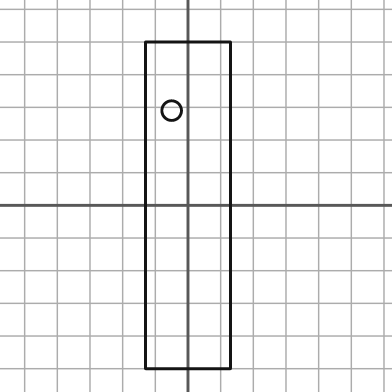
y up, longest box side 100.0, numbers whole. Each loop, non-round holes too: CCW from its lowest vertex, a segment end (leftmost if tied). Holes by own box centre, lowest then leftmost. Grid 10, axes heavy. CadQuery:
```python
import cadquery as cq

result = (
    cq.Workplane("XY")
    .moveTo(-13.0, -50.0)
    .lineTo(13.0, -50.0)
    .lineTo(13.0, 50.0)
    .lineTo(-13.0, 50.0)
    .close()
    .moveTo(-5.0, 29.0)
    .circle(3.0)
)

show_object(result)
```